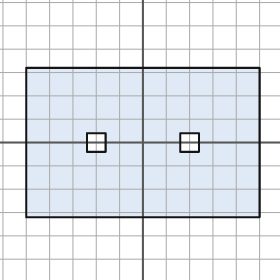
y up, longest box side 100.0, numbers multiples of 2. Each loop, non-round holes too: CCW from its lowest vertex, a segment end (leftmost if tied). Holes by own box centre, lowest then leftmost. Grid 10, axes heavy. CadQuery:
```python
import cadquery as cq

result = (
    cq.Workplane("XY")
    .moveTo(-50.0, -32.0)
    .lineTo(50.0, -32.0)
    .lineTo(50.0, 32.0)
    .lineTo(-50.0, 32.0)
    .close()
    .moveTo(-24.0, -4.0)
    .lineTo(-16.0, -4.0)
    .lineTo(-16.0, 4.0)
    .lineTo(-24.0, 4.0)
    .close()
    .moveTo(16.0, -4.0)
    .lineTo(24.0, -4.0)
    .lineTo(24.0, 4.0)
    .lineTo(16.0, 4.0)
    .close()
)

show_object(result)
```